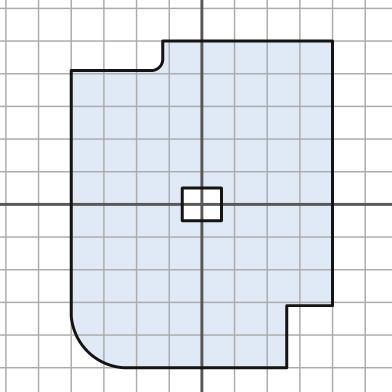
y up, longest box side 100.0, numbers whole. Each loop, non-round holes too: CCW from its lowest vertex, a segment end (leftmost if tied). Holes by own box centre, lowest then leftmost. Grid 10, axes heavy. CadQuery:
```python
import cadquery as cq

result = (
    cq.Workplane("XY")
    .moveTo(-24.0, -50.0)
    .lineTo(26.0, -50.0)
    .lineTo(26.0, -31.0)
    .lineTo(40.0, -31.0)
    .lineTo(40.0, 50.0)
    .lineTo(-12.0, 50.0)
    .lineTo(-12.0, 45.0)
    .threePointArc((-13.0, 42.0), (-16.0, 41.0))
    .lineTo(-40.0, 41.0)
    .lineTo(-40.0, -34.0)
    .threePointArc((-35.0, -45.0), (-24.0, -50.0))
    .close()
    .moveTo(-6.0, -5.0)
    .lineTo(6.0, -5.0)
    .lineTo(6.0, 5.0)
    .lineTo(-6.0, 5.0)
    .close()
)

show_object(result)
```